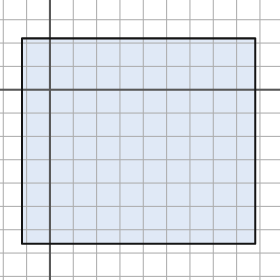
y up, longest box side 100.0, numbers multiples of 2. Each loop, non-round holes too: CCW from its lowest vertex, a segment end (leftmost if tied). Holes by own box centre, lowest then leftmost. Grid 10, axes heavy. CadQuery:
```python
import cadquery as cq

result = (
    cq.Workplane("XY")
    .moveTo(-12.0, -66.0)
    .lineTo(88.0, -66.0)
    .lineTo(88.0, 22.0)
    .lineTo(-12.0, 22.0)
    .close()
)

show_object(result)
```